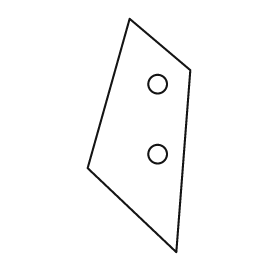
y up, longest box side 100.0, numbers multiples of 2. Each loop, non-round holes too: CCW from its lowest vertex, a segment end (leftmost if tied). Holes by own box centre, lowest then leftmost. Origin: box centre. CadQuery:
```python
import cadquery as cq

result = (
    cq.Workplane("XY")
    .moveTo(16.0, -50.0)
    .lineTo(22.0, 28.0)
    .lineTo(-4.0, 50.0)
    .lineTo(-22.0, -14.0)
    .close()
    .moveTo(8.0, -8.0)
    .circle(4.0)
    .moveTo(8.0, 22.0)
    .circle(4.0)
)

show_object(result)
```